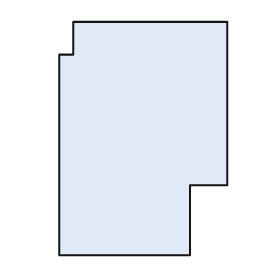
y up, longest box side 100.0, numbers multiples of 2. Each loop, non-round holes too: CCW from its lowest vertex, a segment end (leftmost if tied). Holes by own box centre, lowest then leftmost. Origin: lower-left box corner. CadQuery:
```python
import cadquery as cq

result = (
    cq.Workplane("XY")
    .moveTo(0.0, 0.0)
    .lineTo(56.0, 0.0)
    .lineTo(56.0, 30.0)
    .lineTo(72.0, 30.0)
    .lineTo(72.0, 100.0)
    .lineTo(6.0, 100.0)
    .lineTo(6.0, 86.0)
    .lineTo(0.0, 86.0)
    .close()
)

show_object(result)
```